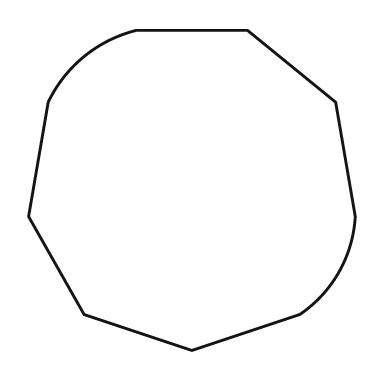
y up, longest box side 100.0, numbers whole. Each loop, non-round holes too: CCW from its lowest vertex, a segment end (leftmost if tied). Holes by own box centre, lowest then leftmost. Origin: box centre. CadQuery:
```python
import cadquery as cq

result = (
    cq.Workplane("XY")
    .moveTo(0.0, -49.0)
    .lineTo(33.0, -38.0)
    .threePointArc((45.0, -25.0), (50.0, -8.0))
    .lineTo(44.0, 27.0)
    .lineTo(17.0, 49.0)
    .lineTo(-17.0, 49.0)
    .threePointArc((-33.0, 41.0), (-44.0, 27.0))
    .lineTo(-50.0, -8.0)
    .lineTo(-33.0, -38.0)
    .close()
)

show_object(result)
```